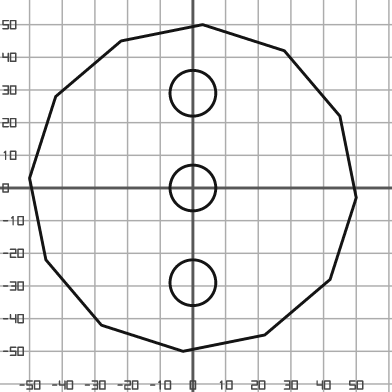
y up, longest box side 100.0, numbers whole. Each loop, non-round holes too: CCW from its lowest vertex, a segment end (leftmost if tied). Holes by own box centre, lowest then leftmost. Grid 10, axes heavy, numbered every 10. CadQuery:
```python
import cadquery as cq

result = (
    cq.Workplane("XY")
    .moveTo(-3.0, -50.0)
    .lineTo(22.0, -45.0)
    .lineTo(42.0, -28.0)
    .lineTo(50.0, -3.0)
    .lineTo(45.0, 22.0)
    .lineTo(28.0, 42.0)
    .lineTo(3.0, 50.0)
    .lineTo(-22.0, 45.0)
    .lineTo(-42.0, 28.0)
    .lineTo(-50.0, 3.0)
    .lineTo(-45.0, -22.0)
    .lineTo(-28.0, -42.0)
    .close()
    .moveTo(0.0, -29.0)
    .circle(7.0)
    .moveTo(0.0, 0.0)
    .circle(7.0)
    .moveTo(0.0, 29.0)
    .circle(7.0)
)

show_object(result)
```